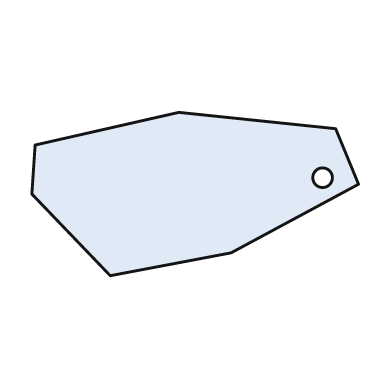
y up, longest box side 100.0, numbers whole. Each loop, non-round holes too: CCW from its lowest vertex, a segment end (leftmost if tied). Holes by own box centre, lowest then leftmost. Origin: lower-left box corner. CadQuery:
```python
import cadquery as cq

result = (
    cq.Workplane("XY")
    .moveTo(24.0, 0.0)
    .lineTo(61.0, 7.0)
    .lineTo(100.0, 28.0)
    .lineTo(93.0, 45.0)
    .lineTo(45.0, 50.0)
    .lineTo(1.0, 40.0)
    .lineTo(0.0, 25.0)
    .close()
    .moveTo(89.0, 30.0)
    .circle(3.0)
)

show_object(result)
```